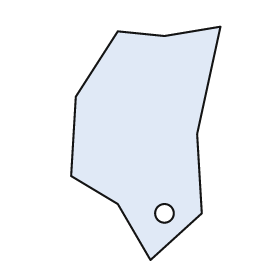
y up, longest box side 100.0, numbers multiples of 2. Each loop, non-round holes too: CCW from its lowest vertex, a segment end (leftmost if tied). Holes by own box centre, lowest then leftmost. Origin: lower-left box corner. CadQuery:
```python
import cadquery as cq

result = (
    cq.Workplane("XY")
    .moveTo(34.0, 0.0)
    .lineTo(56.0, 20.0)
    .lineTo(54.0, 54.0)
    .lineTo(64.0, 100.0)
    .lineTo(40.0, 96.0)
    .lineTo(20.0, 98.0)
    .lineTo(2.0, 70.0)
    .lineTo(0.0, 36.0)
    .lineTo(20.0, 24.0)
    .close()
    .moveTo(40.0, 20.0)
    .circle(4.0)
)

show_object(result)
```